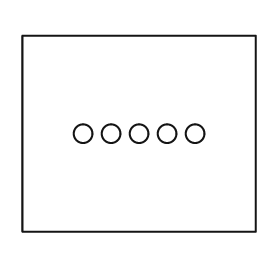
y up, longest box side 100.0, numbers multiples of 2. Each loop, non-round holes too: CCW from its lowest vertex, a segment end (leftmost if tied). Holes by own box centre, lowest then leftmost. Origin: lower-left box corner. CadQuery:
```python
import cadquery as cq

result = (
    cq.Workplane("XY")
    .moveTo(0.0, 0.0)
    .lineTo(100.0, 0.0)
    .lineTo(100.0, 84.0)
    .lineTo(0.0, 84.0)
    .close()
    .moveTo(26.0, 42.0)
    .circle(4.0)
    .moveTo(38.0, 42.0)
    .circle(4.0)
    .moveTo(50.0, 42.0)
    .circle(4.0)
    .moveTo(62.0, 42.0)
    .circle(4.0)
    .moveTo(74.0, 42.0)
    .circle(4.0)
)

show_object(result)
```